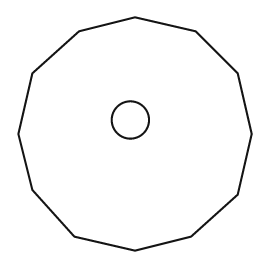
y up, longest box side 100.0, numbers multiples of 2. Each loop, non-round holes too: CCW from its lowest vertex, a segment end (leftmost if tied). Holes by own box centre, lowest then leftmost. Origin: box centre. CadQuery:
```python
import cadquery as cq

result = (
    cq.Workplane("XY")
    .moveTo(0.0, -50.0)
    .lineTo(24.0, -44.0)
    .lineTo(44.0, -26.0)
    .lineTo(50.0, 0.0)
    .lineTo(44.0, 26.0)
    .lineTo(26.0, 44.0)
    .lineTo(0.0, 50.0)
    .lineTo(-24.0, 44.0)
    .lineTo(-44.0, 26.0)
    .lineTo(-50.0, 0.0)
    .lineTo(-44.0, -24.0)
    .lineTo(-26.0, -44.0)
    .close()
    .moveTo(-2.0, 6.0)
    .circle(8.0)
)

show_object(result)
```